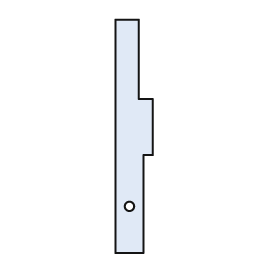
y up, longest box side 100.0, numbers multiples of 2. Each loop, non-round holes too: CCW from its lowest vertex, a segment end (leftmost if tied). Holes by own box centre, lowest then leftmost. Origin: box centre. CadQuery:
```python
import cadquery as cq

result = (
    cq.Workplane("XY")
    .moveTo(-8.0, -50.0)
    .lineTo(4.0, -50.0)
    .lineTo(4.0, -8.0)
    .lineTo(8.0, -8.0)
    .lineTo(8.0, 16.0)
    .lineTo(2.0, 16.0)
    .lineTo(2.0, 50.0)
    .lineTo(-8.0, 50.0)
    .close()
    .moveTo(-2.0, -30.0)
    .circle(2.0)
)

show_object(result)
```